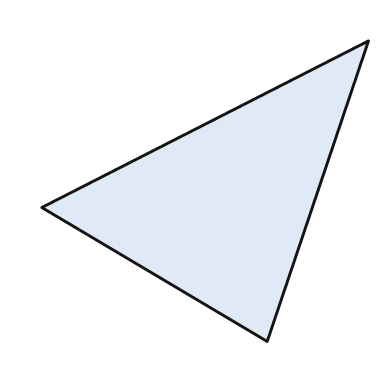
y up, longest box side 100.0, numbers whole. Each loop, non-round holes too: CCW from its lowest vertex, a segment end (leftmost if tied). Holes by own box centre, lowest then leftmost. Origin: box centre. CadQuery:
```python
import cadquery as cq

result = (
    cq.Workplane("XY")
    .moveTo(19.0, -46.0)
    .lineTo(50.0, 46.0)
    .lineTo(-50.0, -5.0)
    .close()
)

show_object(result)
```